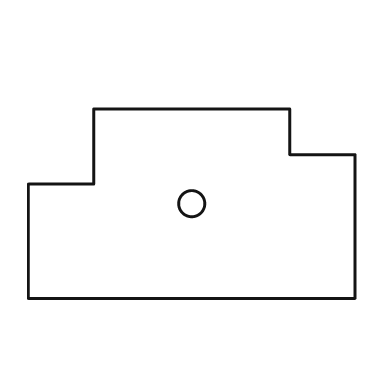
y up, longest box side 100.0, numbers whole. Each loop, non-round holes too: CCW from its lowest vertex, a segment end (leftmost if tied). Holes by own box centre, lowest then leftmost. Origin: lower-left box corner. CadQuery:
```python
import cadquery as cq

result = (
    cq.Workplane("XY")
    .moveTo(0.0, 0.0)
    .lineTo(100.0, 0.0)
    .lineTo(100.0, 44.0)
    .lineTo(80.0, 44.0)
    .lineTo(80.0, 58.0)
    .lineTo(20.0, 58.0)
    .lineTo(20.0, 35.0)
    .lineTo(0.0, 35.0)
    .close()
    .moveTo(50.0, 29.0)
    .circle(4.0)
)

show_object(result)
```